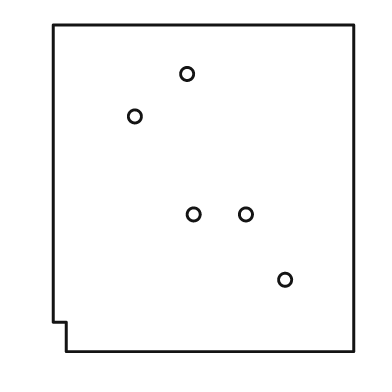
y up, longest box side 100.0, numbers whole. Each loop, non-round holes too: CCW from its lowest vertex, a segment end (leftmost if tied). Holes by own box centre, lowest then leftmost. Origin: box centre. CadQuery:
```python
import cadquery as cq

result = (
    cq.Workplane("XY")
    .moveTo(-42.0, -50.0)
    .lineTo(46.0, -50.0)
    .lineTo(46.0, 50.0)
    .lineTo(-46.0, 50.0)
    .lineTo(-46.0, -41.0)
    .lineTo(-42.0, -41.0)
    .close()
    .moveTo(25.0, -28.0)
    .circle(2.0)
    .moveTo(-3.0, -8.0)
    .circle(2.0)
    .moveTo(13.0, -8.0)
    .circle(2.0)
    .moveTo(-21.0, 22.0)
    .circle(2.0)
    .moveTo(-5.0, 35.0)
    .circle(2.0)
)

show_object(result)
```